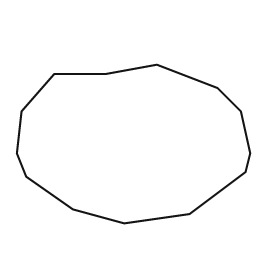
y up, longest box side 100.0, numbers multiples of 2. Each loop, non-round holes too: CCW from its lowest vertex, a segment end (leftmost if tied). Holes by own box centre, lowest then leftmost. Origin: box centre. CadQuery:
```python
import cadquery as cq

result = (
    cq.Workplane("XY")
    .moveTo(-4.0, -34.0)
    .lineTo(24.0, -30.0)
    .lineTo(48.0, -12.0)
    .lineTo(50.0, -4.0)
    .lineTo(46.0, 14.0)
    .lineTo(36.0, 24.0)
    .lineTo(10.0, 34.0)
    .lineTo(-12.0, 30.0)
    .lineTo(-34.0, 30.0)
    .lineTo(-48.0, 14.0)
    .lineTo(-50.0, -4.0)
    .lineTo(-46.0, -14.0)
    .lineTo(-26.0, -28.0)
    .close()
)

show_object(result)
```